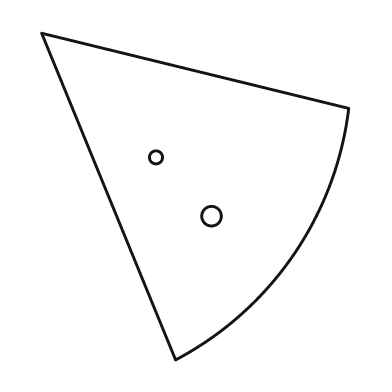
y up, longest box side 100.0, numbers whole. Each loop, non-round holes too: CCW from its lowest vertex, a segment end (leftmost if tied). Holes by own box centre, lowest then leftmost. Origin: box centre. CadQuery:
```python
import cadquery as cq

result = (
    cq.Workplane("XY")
    .moveTo(-6.0, -50.0)
    .threePointArc((30.0, -18.0), (47.0, 27.0))
    .lineTo(-47.0, 50.0)
    .close()
    .moveTo(5.0, -6.0)
    .circle(3.0)
    .moveTo(-12.0, 12.0)
    .circle(2.0)
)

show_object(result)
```